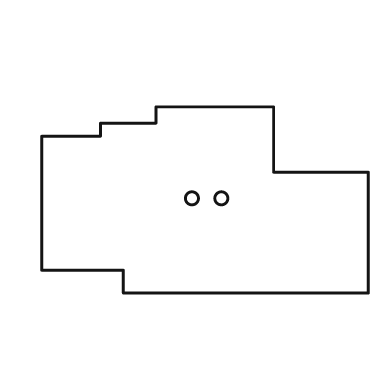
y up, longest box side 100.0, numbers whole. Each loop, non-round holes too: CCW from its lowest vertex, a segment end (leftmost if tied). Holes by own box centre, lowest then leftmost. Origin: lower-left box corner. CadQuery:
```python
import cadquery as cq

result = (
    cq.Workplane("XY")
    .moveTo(25.0, 0.0)
    .lineTo(100.0, 0.0)
    .lineTo(100.0, 37.0)
    .lineTo(71.0, 37.0)
    .lineTo(71.0, 57.0)
    .lineTo(35.0, 57.0)
    .lineTo(35.0, 52.0)
    .lineTo(18.0, 52.0)
    .lineTo(18.0, 48.0)
    .lineTo(0.0, 48.0)
    .lineTo(0.0, 7.0)
    .lineTo(25.0, 7.0)
    .close()
    .moveTo(46.0, 29.0)
    .circle(2.0)
    .moveTo(55.0, 29.0)
    .circle(2.0)
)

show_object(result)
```